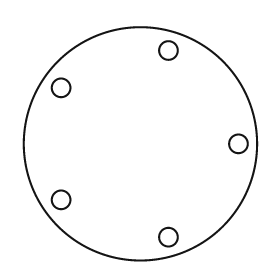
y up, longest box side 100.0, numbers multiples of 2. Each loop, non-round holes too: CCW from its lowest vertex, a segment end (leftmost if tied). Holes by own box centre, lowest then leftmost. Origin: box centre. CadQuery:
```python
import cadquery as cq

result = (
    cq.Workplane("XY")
    .moveTo(0.0, 0.0)
    .circle(50.0)
    .moveTo(12.0, -40.0)
    .circle(4.0)
    .moveTo(-34.0, -24.0)
    .circle(4.0)
    .moveTo(42.0, 0.0)
    .circle(4.0)
    .moveTo(-34.0, 24.0)
    .circle(4.0)
    .moveTo(12.0, 40.0)
    .circle(4.0)
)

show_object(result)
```